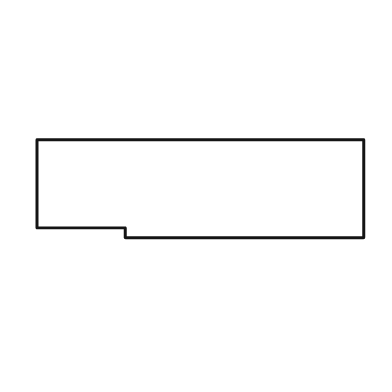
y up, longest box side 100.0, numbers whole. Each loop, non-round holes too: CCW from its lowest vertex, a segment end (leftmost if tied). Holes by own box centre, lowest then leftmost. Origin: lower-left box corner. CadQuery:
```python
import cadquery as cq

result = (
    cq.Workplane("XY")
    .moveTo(27.0, 0.0)
    .lineTo(100.0, 0.0)
    .lineTo(100.0, 30.0)
    .lineTo(0.0, 30.0)
    .lineTo(0.0, 3.0)
    .lineTo(27.0, 3.0)
    .close()
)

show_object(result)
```